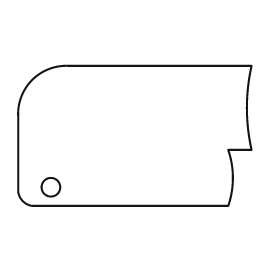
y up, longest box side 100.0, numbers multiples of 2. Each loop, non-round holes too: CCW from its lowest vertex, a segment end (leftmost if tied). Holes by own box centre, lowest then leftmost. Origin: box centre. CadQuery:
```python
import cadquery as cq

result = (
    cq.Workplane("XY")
    .moveTo(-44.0, -30.0)
    .lineTo(40.0, -30.0)
    .threePointArc((42.0, -18.0), (40.0, -6.0))
    .lineTo(50.0, -6.0)
    .threePointArc((48.0, 12.0), (50.0, 30.0))
    .lineTo(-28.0, 30.0)
    .threePointArc((-44.0, 24.0), (-50.0, 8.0))
    .lineTo(-50.0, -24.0)
    .threePointArc((-48.0, -28.0), (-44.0, -30.0))
    .close()
    .moveTo(-36.0, -22.0)
    .circle(4.0)
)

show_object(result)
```